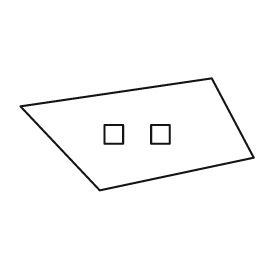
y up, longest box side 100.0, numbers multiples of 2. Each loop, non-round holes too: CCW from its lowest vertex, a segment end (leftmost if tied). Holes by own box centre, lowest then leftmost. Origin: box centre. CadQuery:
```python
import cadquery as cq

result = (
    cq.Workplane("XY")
    .moveTo(-16.0, -24.0)
    .lineTo(50.0, -10.0)
    .lineTo(32.0, 24.0)
    .lineTo(-50.0, 12.0)
    .close()
    .moveTo(-14.0, -4.0)
    .lineTo(-6.0, -4.0)
    .lineTo(-6.0, 4.0)
    .lineTo(-14.0, 4.0)
    .close()
    .moveTo(6.0, -4.0)
    .lineTo(14.0, -4.0)
    .lineTo(14.0, 4.0)
    .lineTo(6.0, 4.0)
    .close()
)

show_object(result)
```